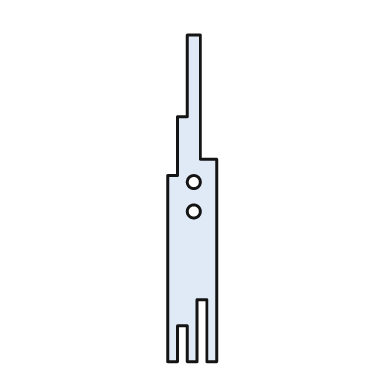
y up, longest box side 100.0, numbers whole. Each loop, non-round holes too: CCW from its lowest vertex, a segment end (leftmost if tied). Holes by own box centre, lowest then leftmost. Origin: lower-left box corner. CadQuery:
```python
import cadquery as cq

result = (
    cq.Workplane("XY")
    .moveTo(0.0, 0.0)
    .lineTo(3.0, 0.0)
    .lineTo(3.0, 11.0)
    .lineTo(6.0, 11.0)
    .lineTo(6.0, 0.0)
    .lineTo(9.0, 0.0)
    .lineTo(9.0, 19.0)
    .lineTo(12.0, 19.0)
    .lineTo(12.0, 0.0)
    .lineTo(15.0, 0.0)
    .lineTo(15.0, 62.0)
    .lineTo(10.0, 62.0)
    .lineTo(10.0, 100.0)
    .lineTo(6.0, 100.0)
    .lineTo(6.0, 75.0)
    .lineTo(3.0, 75.0)
    .lineTo(3.0, 57.0)
    .lineTo(0.0, 57.0)
    .close()
    .moveTo(8.0, 46.0)
    .circle(2.0)
    .moveTo(8.0, 55.0)
    .circle(2.0)
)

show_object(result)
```